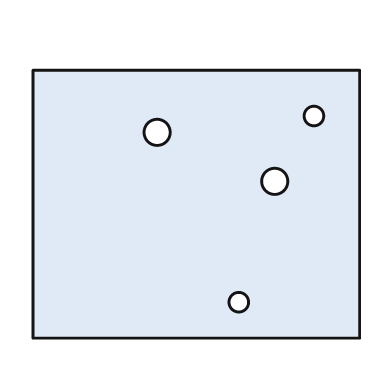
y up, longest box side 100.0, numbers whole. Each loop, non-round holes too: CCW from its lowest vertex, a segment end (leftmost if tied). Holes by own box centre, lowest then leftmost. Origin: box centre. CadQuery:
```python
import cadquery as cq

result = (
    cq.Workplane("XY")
    .moveTo(-50.0, -41.0)
    .lineTo(50.0, -41.0)
    .lineTo(50.0, 41.0)
    .lineTo(-50.0, 41.0)
    .close()
    .moveTo(13.0, -30.0)
    .circle(3.0)
    .moveTo(24.0, 7.0)
    .circle(4.0)
    .moveTo(-12.0, 22.0)
    .circle(4.0)
    .moveTo(36.0, 27.0)
    .circle(3.0)
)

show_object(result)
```